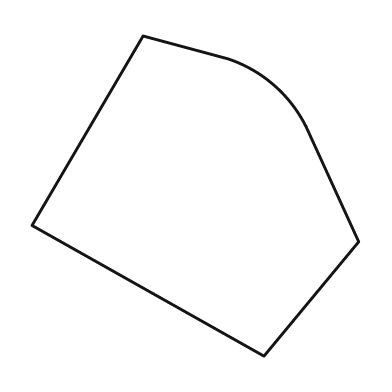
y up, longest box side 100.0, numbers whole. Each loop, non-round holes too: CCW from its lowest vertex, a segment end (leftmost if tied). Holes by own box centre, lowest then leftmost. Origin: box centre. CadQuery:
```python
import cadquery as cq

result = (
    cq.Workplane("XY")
    .moveTo(21.0, -49.0)
    .lineTo(50.0, -14.0)
    .lineTo(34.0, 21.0)
    .threePointArc((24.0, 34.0), (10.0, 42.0))
    .lineTo(-16.0, 49.0)
    .lineTo(-50.0, -9.0)
    .close()
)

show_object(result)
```